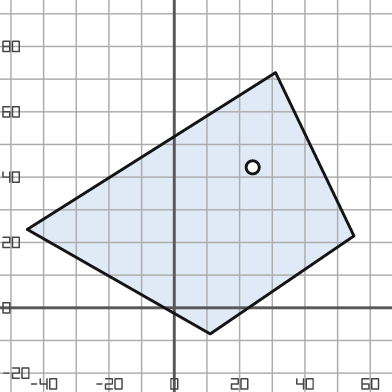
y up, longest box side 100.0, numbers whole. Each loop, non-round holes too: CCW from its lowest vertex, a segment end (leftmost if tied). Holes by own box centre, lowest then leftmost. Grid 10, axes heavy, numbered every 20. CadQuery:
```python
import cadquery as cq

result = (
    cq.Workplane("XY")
    .moveTo(11.0, -8.0)
    .lineTo(55.0, 22.0)
    .lineTo(31.0, 72.0)
    .lineTo(-45.0, 24.0)
    .close()
    .moveTo(24.0, 43.0)
    .circle(2.0)
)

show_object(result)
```